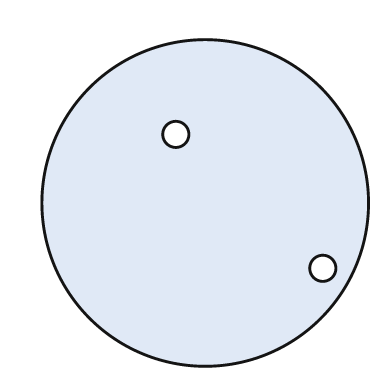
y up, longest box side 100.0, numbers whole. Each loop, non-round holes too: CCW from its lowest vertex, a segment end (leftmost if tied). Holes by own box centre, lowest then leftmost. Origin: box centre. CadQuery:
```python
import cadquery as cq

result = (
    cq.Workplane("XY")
    .moveTo(0.0, 0.0)
    .circle(50.0)
    .moveTo(36.0, -20.0)
    .circle(4.0)
    .moveTo(-9.0, 21.0)
    .circle(4.0)
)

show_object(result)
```